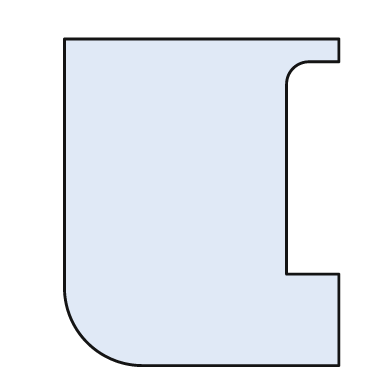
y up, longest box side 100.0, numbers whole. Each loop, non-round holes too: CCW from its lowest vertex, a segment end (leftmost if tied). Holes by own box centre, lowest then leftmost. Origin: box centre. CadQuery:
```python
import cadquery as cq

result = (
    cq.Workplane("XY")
    .moveTo(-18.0, -50.0)
    .lineTo(42.0, -50.0)
    .lineTo(42.0, -22.0)
    .lineTo(26.0, -22.0)
    .lineTo(26.0, 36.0)
    .threePointArc((28.0, 41.0), (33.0, 43.0))
    .lineTo(42.0, 43.0)
    .lineTo(42.0, 50.0)
    .lineTo(-42.0, 50.0)
    .lineTo(-42.0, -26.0)
    .threePointArc((-35.0, -43.0), (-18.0, -50.0))
    .close()
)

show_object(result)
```